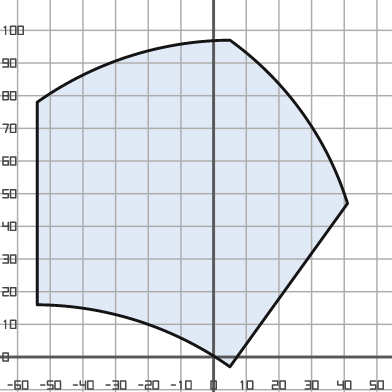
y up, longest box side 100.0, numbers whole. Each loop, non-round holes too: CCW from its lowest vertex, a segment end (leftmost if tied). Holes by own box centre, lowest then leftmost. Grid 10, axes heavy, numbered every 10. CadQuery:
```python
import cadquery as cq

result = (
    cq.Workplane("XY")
    .moveTo(5.0, -3.0)
    .lineTo(41.0, 47.0)
    .threePointArc((27.0, 75.0), (5.0, 97.0))
    .threePointArc((-26.0, 92.0), (-54.0, 78.0))
    .lineTo(-54.0, 16.0)
    .threePointArc((-23.0, 11.0), (5.0, -3.0))
    .close()
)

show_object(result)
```